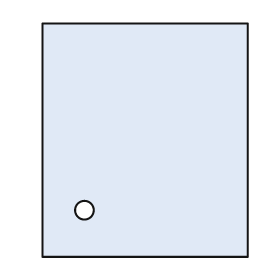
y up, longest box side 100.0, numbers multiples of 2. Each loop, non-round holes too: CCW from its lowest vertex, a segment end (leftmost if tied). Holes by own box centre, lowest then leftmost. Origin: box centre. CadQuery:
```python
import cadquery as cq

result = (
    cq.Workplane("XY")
    .moveTo(-44.0, -50.0)
    .lineTo(44.0, -50.0)
    .lineTo(44.0, 50.0)
    .lineTo(-44.0, 50.0)
    .close()
    .moveTo(-26.0, -30.0)
    .circle(4.0)
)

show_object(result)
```